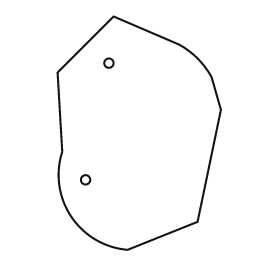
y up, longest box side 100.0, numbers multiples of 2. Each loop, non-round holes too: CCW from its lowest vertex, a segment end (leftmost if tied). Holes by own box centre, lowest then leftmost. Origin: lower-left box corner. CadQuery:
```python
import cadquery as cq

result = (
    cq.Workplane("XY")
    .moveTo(30.0, 0.0)
    .lineTo(60.0, 12.0)
    .lineTo(70.0, 60.0)
    .lineTo(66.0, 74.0)
    .threePointArc((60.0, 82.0), (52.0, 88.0))
    .lineTo(24.0, 100.0)
    .lineTo(0.0, 76.0)
    .lineTo(2.0, 42.0)
    .threePointArc((6.0, 14.0), (30.0, 0.0))
    .close()
    .moveTo(12.0, 30.0)
    .circle(2.0)
    .moveTo(22.0, 80.0)
    .circle(2.0)
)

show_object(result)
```